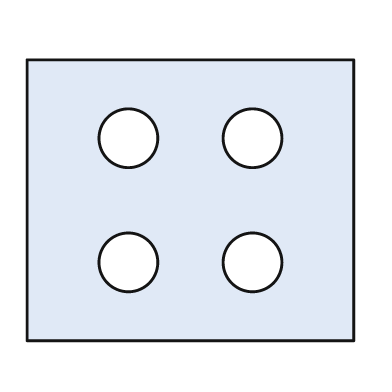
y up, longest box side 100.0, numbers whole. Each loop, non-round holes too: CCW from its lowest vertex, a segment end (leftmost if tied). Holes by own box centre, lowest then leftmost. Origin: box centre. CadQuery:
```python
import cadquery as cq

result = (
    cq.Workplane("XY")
    .moveTo(-50.0, -43.0)
    .lineTo(50.0, -43.0)
    .lineTo(50.0, 43.0)
    .lineTo(-50.0, 43.0)
    .close()
    .moveTo(-19.0, -19.0)
    .circle(9.0)
    .moveTo(19.0, -19.0)
    .circle(9.0)
    .moveTo(-19.0, 19.0)
    .circle(9.0)
    .moveTo(19.0, 19.0)
    .circle(9.0)
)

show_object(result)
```